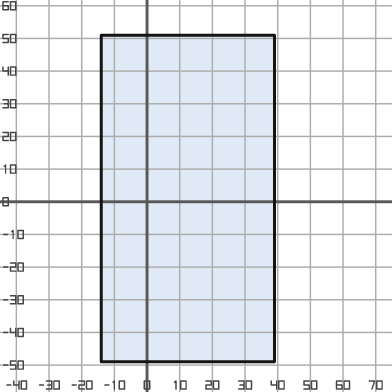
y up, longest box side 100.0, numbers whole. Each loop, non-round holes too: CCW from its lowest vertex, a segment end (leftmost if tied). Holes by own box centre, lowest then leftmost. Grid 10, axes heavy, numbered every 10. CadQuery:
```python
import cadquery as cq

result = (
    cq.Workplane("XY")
    .moveTo(-14.0, -49.0)
    .lineTo(39.0, -49.0)
    .lineTo(39.0, 51.0)
    .lineTo(-14.0, 51.0)
    .close()
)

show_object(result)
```